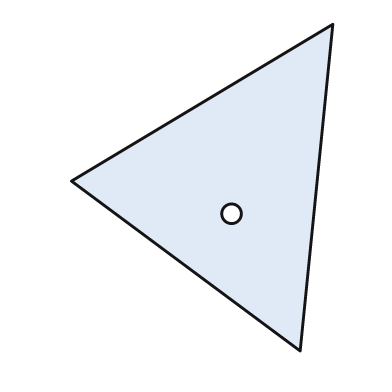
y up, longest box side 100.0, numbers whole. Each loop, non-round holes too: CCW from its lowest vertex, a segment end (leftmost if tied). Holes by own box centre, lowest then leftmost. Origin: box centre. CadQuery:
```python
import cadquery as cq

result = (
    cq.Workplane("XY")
    .moveTo(30.0, -50.0)
    .lineTo(40.0, 50.0)
    .lineTo(-40.0, 2.0)
    .close()
    .moveTo(9.0, -8.0)
    .circle(3.0)
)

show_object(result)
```